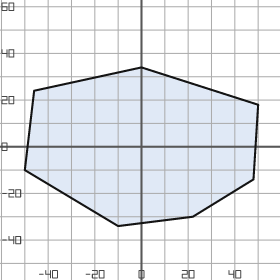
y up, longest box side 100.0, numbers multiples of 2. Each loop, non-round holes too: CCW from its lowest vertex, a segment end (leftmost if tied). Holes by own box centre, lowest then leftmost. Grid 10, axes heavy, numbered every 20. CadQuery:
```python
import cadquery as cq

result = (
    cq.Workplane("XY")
    .moveTo(-10.0, -34.0)
    .lineTo(22.0, -30.0)
    .lineTo(48.0, -14.0)
    .lineTo(50.0, 18.0)
    .lineTo(0.0, 34.0)
    .lineTo(-46.0, 24.0)
    .lineTo(-50.0, -10.0)
    .close()
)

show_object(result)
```